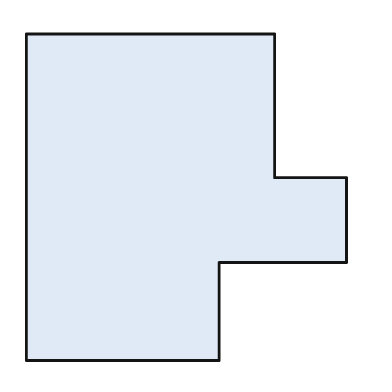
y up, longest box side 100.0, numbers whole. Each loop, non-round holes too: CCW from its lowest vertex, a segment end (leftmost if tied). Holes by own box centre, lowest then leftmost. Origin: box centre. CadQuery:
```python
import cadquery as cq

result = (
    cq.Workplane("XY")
    .moveTo(-49.0, -50.0)
    .lineTo(10.0, -50.0)
    .lineTo(10.0, -20.0)
    .lineTo(49.0, -20.0)
    .lineTo(49.0, 6.0)
    .lineTo(27.0, 6.0)
    .lineTo(27.0, 50.0)
    .lineTo(-49.0, 50.0)
    .close()
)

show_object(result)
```